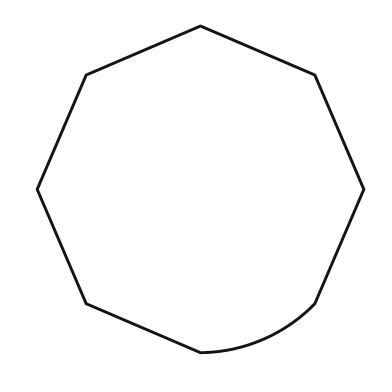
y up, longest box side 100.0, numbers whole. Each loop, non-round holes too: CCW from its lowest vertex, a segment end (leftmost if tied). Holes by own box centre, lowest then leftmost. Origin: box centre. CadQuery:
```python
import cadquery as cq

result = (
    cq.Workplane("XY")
    .moveTo(0.0, -50.0)
    .threePointArc((19.0, -46.0), (35.0, -35.0))
    .lineTo(50.0, 0.0)
    .lineTo(35.0, 35.0)
    .lineTo(0.0, 50.0)
    .lineTo(-35.0, 35.0)
    .lineTo(-50.0, 0.0)
    .lineTo(-35.0, -35.0)
    .close()
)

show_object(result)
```